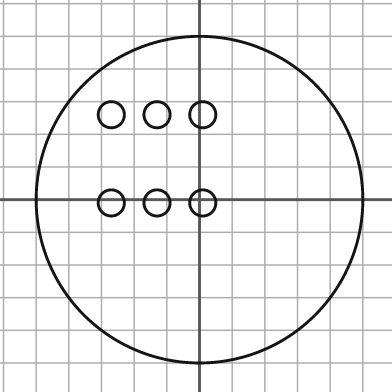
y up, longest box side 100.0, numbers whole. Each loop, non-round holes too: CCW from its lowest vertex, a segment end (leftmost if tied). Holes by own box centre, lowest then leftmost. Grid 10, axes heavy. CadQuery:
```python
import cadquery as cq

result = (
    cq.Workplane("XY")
    .moveTo(0.0, 0.0)
    .circle(50.0)
    .moveTo(-27.0, -1.0)
    .circle(4.0)
    .moveTo(-13.0, -1.0)
    .circle(4.0)
    .moveTo(1.0, -1.0)
    .circle(4.0)
    .moveTo(-27.0, 26.0)
    .circle(4.0)
    .moveTo(-13.0, 26.0)
    .circle(4.0)
    .moveTo(1.0, 26.0)
    .circle(4.0)
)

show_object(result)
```